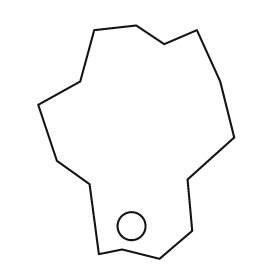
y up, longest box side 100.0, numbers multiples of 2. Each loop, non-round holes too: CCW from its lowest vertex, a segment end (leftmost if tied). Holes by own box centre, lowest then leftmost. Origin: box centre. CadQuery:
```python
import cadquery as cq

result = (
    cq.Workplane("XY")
    .moveTo(10.0, -50.0)
    .lineTo(24.0, -38.0)
    .lineTo(22.0, -16.0)
    .lineTo(42.0, 2.0)
    .lineTo(36.0, 26.0)
    .lineTo(26.0, 48.0)
    .lineTo(12.0, 42.0)
    .lineTo(0.0, 50.0)
    .lineTo(-18.0, 48.0)
    .lineTo(-24.0, 26.0)
    .lineTo(-42.0, 16.0)
    .lineTo(-34.0, -8.0)
    .lineTo(-20.0, -18.0)
    .lineTo(-16.0, -48.0)
    .lineTo(-6.0, -46.0)
    .close()
    .moveTo(-2.0, -36.0)
    .circle(6.0)
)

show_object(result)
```